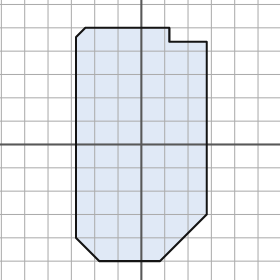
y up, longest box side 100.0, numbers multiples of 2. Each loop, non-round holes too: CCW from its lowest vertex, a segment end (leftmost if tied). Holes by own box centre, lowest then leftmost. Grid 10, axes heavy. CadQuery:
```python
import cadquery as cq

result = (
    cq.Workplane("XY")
    .moveTo(-18.0, -50.0)
    .lineTo(8.0, -50.0)
    .lineTo(28.0, -30.0)
    .lineTo(28.0, 44.0)
    .lineTo(12.0, 44.0)
    .lineTo(12.0, 50.0)
    .lineTo(-24.0, 50.0)
    .lineTo(-28.0, 46.0)
    .lineTo(-28.0, -40.0)
    .close()
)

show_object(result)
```